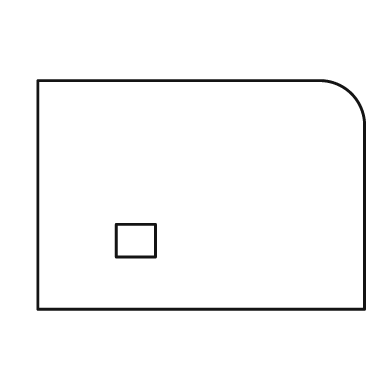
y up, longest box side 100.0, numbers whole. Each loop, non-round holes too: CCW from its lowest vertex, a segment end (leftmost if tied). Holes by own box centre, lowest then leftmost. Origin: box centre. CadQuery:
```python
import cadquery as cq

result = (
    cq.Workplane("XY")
    .moveTo(-50.0, -35.0)
    .lineTo(50.0, -35.0)
    .lineTo(50.0, 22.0)
    .threePointArc((46.0, 31.0), (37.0, 35.0))
    .lineTo(-50.0, 35.0)
    .close()
    .moveTo(-26.0, -19.0)
    .lineTo(-14.0, -19.0)
    .lineTo(-14.0, -9.0)
    .lineTo(-26.0, -9.0)
    .close()
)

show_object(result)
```